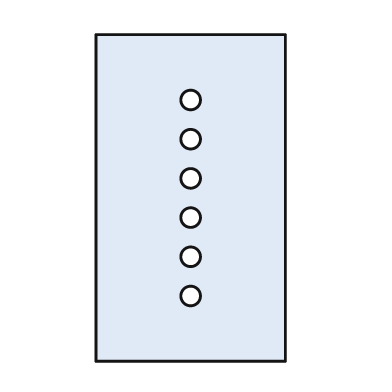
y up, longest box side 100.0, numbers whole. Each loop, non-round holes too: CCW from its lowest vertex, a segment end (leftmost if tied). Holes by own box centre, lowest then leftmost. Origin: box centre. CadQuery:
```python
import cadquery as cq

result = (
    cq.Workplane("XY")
    .moveTo(-29.0, -50.0)
    .lineTo(29.0, -50.0)
    .lineTo(29.0, 50.0)
    .lineTo(-29.0, 50.0)
    .close()
    .moveTo(0.0, -30.0)
    .circle(3.0)
    .moveTo(0.0, -18.0)
    .circle(3.0)
    .moveTo(0.0, -6.0)
    .circle(3.0)
    .moveTo(0.0, 6.0)
    .circle(3.0)
    .moveTo(0.0, 18.0)
    .circle(3.0)
    .moveTo(0.0, 30.0)
    .circle(3.0)
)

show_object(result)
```